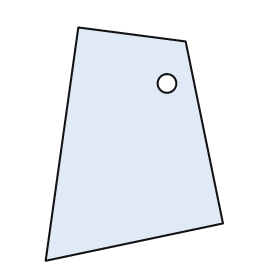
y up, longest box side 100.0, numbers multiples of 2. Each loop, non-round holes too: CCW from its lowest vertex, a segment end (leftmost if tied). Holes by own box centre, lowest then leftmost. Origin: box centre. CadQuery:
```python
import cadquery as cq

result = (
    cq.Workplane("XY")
    .moveTo(-38.0, -50.0)
    .lineTo(38.0, -34.0)
    .lineTo(22.0, 44.0)
    .lineTo(-24.0, 50.0)
    .close()
    .moveTo(14.0, 26.0)
    .circle(4.0)
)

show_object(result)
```